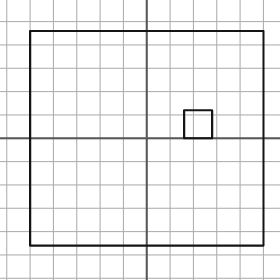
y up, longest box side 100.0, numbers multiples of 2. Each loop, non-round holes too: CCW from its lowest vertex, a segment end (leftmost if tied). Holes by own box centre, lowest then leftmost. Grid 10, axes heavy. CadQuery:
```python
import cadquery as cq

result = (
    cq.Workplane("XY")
    .moveTo(-50.0, -46.0)
    .lineTo(50.0, -46.0)
    .lineTo(50.0, 46.0)
    .lineTo(-50.0, 46.0)
    .close()
    .moveTo(16.0, 0.0)
    .lineTo(28.0, 0.0)
    .lineTo(28.0, 12.0)
    .lineTo(16.0, 12.0)
    .close()
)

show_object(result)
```